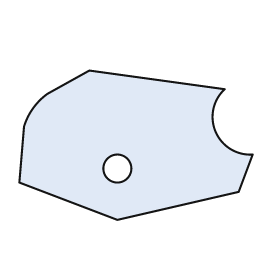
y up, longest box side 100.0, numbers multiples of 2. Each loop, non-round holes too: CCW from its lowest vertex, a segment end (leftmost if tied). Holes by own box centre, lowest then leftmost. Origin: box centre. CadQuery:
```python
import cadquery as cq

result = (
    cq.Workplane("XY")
    .moveTo(-8.0, -32.0)
    .lineTo(44.0, -20.0)
    .lineTo(50.0, -4.0)
    .threePointArc((34.0, 6.0), (38.0, 24.0))
    .lineTo(-20.0, 32.0)
    .lineTo(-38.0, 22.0)
    .threePointArc((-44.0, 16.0), (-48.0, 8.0))
    .lineTo(-50.0, -16.0)
    .close()
    .moveTo(-8.0, -10.0)
    .circle(6.0)
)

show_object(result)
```